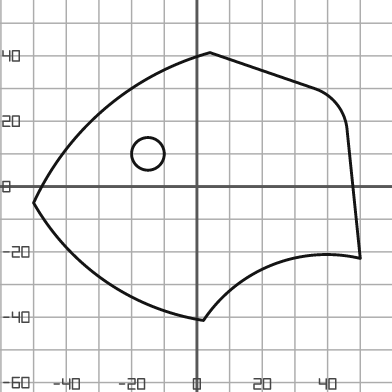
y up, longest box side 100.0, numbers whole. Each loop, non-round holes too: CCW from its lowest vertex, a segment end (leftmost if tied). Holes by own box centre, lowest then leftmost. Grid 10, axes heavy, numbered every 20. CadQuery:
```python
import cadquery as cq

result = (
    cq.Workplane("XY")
    .moveTo(2.0, -41.0)
    .threePointArc((23.0, -24.0), (50.0, -22.0))
    .lineTo(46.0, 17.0)
    .threePointArc((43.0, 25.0), (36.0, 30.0))
    .lineTo(4.0, 41.0)
    .threePointArc((-28.0, 24.0), (-50.0, -5.0))
    .threePointArc((-28.0, -29.0), (2.0, -41.0))
    .close()
    .moveTo(-15.0, 10.0)
    .circle(5.0)
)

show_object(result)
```